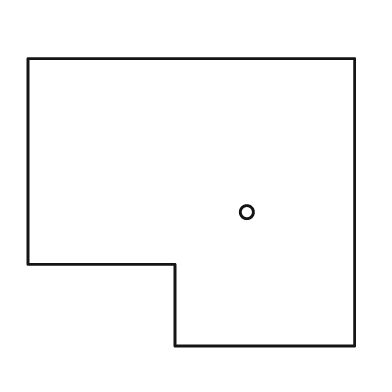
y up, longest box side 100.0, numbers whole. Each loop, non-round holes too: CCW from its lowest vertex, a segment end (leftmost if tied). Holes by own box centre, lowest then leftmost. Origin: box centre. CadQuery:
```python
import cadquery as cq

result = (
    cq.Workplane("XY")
    .moveTo(-5.0, -44.0)
    .lineTo(50.0, -44.0)
    .lineTo(50.0, 44.0)
    .lineTo(-50.0, 44.0)
    .lineTo(-50.0, -19.0)
    .lineTo(-5.0, -19.0)
    .close()
    .moveTo(17.0, -3.0)
    .circle(2.0)
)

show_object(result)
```